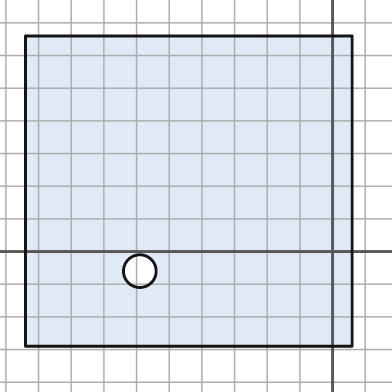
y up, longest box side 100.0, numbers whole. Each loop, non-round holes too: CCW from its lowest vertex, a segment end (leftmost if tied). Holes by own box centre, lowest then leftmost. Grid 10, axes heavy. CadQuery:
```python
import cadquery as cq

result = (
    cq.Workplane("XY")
    .moveTo(-94.0, -29.0)
    .lineTo(6.0, -29.0)
    .lineTo(6.0, 66.0)
    .lineTo(-94.0, 66.0)
    .close()
    .moveTo(-59.0, -6.0)
    .circle(5.0)
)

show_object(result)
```